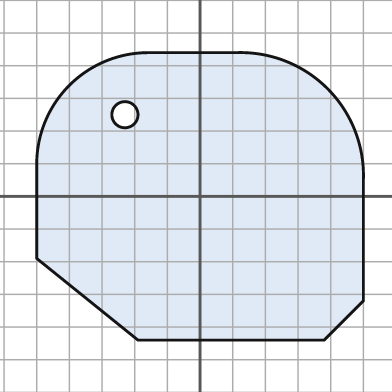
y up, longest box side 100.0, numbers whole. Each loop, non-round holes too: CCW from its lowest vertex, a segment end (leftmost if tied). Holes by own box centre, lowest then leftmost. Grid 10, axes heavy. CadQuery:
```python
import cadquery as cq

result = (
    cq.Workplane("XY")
    .moveTo(-19.0, -44.0)
    .lineTo(38.0, -44.0)
    .lineTo(50.0, -32.0)
    .lineTo(50.0, 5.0)
    .threePointArc((39.0, 33.0), (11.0, 44.0))
    .lineTo(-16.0, 44.0)
    .threePointArc((-40.0, 34.0), (-50.0, 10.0))
    .lineTo(-50.0, -19.0)
    .close()
    .moveTo(-23.0, 25.0)
    .circle(4.0)
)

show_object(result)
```